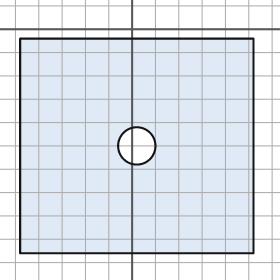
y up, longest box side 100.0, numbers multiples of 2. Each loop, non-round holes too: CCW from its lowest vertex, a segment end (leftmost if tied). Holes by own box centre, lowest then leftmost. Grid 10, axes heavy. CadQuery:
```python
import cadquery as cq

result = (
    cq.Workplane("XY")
    .moveTo(-48.0, -96.0)
    .lineTo(52.0, -96.0)
    .lineTo(52.0, -4.0)
    .lineTo(-48.0, -4.0)
    .close()
    .moveTo(2.0, -50.0)
    .circle(8.0)
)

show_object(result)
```